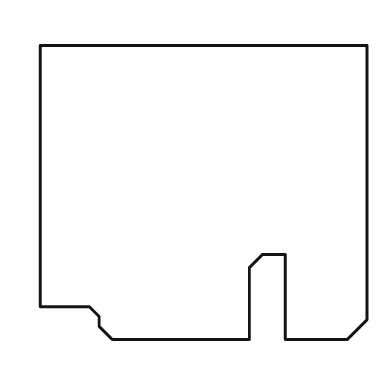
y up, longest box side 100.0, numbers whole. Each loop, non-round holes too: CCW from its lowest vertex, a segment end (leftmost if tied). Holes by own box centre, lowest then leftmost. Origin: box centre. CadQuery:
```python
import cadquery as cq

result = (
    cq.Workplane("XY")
    .moveTo(-28.0, -45.0)
    .lineTo(14.0, -45.0)
    .lineTo(14.0, -23.0)
    .lineTo(18.0, -19.0)
    .lineTo(25.0, -19.0)
    .lineTo(25.0, -45.0)
    .lineTo(44.0, -45.0)
    .lineTo(50.0, -39.0)
    .lineTo(50.0, 45.0)
    .lineTo(-50.0, 45.0)
    .lineTo(-50.0, -35.0)
    .lineTo(-35.0, -35.0)
    .lineTo(-32.0, -38.0)
    .lineTo(-32.0, -41.0)
    .close()
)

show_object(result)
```